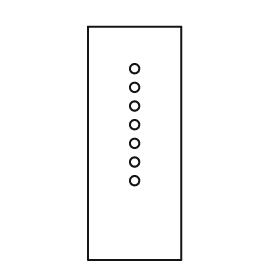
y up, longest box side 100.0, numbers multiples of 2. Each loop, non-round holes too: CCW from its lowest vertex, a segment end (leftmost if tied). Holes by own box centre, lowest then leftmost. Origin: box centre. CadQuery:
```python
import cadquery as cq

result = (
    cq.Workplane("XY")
    .moveTo(-20.0, -50.0)
    .lineTo(20.0, -50.0)
    .lineTo(20.0, 50.0)
    .lineTo(-20.0, 50.0)
    .close()
    .moveTo(0.0, -16.0)
    .circle(2.0)
    .moveTo(0.0, -8.0)
    .circle(2.0)
    .moveTo(0.0, 0.0)
    .circle(2.0)
    .moveTo(0.0, 8.0)
    .circle(2.0)
    .moveTo(0.0, 16.0)
    .circle(2.0)
    .moveTo(0.0, 24.0)
    .circle(2.0)
    .moveTo(0.0, 32.0)
    .circle(2.0)
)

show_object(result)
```